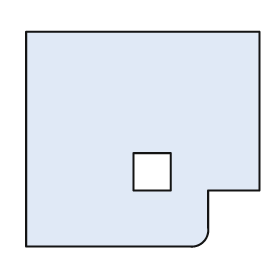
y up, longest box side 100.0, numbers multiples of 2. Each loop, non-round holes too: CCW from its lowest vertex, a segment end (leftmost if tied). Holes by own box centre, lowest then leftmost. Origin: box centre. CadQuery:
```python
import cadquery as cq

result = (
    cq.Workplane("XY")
    .moveTo(-50.0, -46.0)
    .lineTo(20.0, -46.0)
    .threePointArc((26.0, -44.0), (28.0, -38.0))
    .lineTo(28.0, -22.0)
    .lineTo(50.0, -22.0)
    .lineTo(50.0, 46.0)
    .lineTo(-50.0, 46.0)
    .close()
    .moveTo(-4.0, -22.0)
    .lineTo(12.0, -22.0)
    .lineTo(12.0, -6.0)
    .lineTo(-4.0, -6.0)
    .close()
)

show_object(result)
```